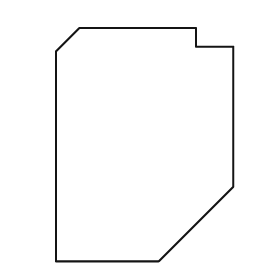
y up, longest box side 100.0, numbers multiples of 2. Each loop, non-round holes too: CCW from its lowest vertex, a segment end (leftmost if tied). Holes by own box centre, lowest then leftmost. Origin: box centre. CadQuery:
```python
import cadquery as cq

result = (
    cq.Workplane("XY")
    .moveTo(-38.0, -50.0)
    .lineTo(6.0, -50.0)
    .lineTo(38.0, -18.0)
    .lineTo(38.0, 42.0)
    .lineTo(22.0, 42.0)
    .lineTo(22.0, 50.0)
    .lineTo(-28.0, 50.0)
    .lineTo(-38.0, 40.0)
    .close()
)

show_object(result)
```